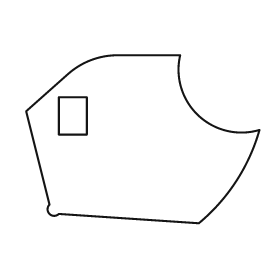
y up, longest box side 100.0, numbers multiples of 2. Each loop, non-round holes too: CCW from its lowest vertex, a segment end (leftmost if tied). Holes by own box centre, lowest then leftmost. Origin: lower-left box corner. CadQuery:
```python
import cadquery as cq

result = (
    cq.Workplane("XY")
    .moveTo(74.0, 0.0)
    .threePointArc((90.0, 18.0), (100.0, 40.0))
    .threePointArc((74.0, 46.0), (66.0, 72.0))
    .lineTo(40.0, 72.0)
    .threePointArc((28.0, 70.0), (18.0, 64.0))
    .lineTo(0.0, 48.0)
    .lineTo(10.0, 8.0)
    .threePointArc((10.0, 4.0), (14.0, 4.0))
    .close()
    .moveTo(14.0, 38.0)
    .lineTo(26.0, 38.0)
    .lineTo(26.0, 54.0)
    .lineTo(14.0, 54.0)
    .close()
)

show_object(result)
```